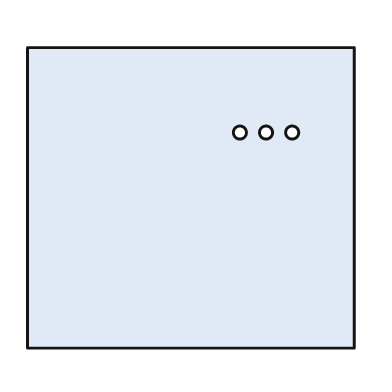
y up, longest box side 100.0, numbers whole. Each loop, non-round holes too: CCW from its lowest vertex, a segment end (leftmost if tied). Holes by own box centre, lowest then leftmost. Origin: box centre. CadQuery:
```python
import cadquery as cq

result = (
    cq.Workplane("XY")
    .moveTo(-50.0, -46.0)
    .lineTo(50.0, -46.0)
    .lineTo(50.0, 46.0)
    .lineTo(-50.0, 46.0)
    .close()
    .moveTo(15.0, 20.0)
    .circle(2.0)
    .moveTo(23.0, 20.0)
    .circle(2.0)
    .moveTo(31.0, 20.0)
    .circle(2.0)
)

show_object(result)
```